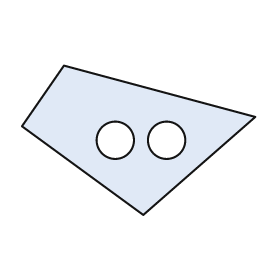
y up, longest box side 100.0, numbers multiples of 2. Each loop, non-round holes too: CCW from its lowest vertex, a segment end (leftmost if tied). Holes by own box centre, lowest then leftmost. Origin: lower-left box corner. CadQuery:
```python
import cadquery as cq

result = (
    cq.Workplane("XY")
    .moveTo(52.0, 0.0)
    .lineTo(100.0, 42.0)
    .lineTo(18.0, 64.0)
    .lineTo(0.0, 38.0)
    .close()
    .moveTo(40.0, 32.0)
    .circle(8.0)
    .moveTo(62.0, 32.0)
    .circle(8.0)
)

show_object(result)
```